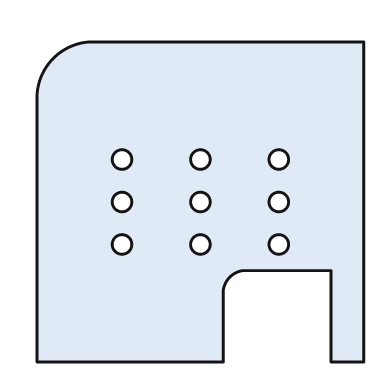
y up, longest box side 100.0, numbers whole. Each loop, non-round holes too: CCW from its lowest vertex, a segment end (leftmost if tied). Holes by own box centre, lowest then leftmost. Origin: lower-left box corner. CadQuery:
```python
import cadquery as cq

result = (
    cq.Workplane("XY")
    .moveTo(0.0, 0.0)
    .lineTo(57.0, 0.0)
    .lineTo(57.0, 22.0)
    .threePointArc((59.0, 26.0), (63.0, 28.0))
    .lineTo(90.0, 28.0)
    .lineTo(90.0, 0.0)
    .lineTo(100.0, 0.0)
    .lineTo(100.0, 98.0)
    .lineTo(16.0, 98.0)
    .threePointArc((5.0, 93.0), (0.0, 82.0))
    .close()
    .moveTo(26.0, 36.0)
    .circle(3.0)
    .moveTo(50.0, 36.0)
    .circle(3.0)
    .moveTo(74.0, 36.0)
    .circle(3.0)
    .moveTo(26.0, 49.0)
    .circle(3.0)
    .moveTo(50.0, 49.0)
    .circle(3.0)
    .moveTo(74.0, 49.0)
    .circle(3.0)
    .moveTo(26.0, 62.0)
    .circle(3.0)
    .moveTo(50.0, 62.0)
    .circle(3.0)
    .moveTo(74.0, 62.0)
    .circle(3.0)
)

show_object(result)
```